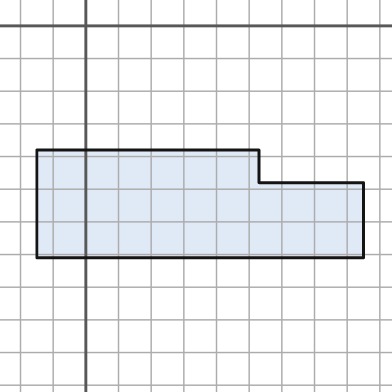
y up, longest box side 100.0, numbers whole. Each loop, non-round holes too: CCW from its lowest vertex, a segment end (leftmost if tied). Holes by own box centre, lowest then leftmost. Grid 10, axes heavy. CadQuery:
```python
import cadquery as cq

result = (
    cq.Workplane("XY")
    .moveTo(-15.0, -71.0)
    .lineTo(85.0, -71.0)
    .lineTo(85.0, -48.0)
    .lineTo(53.0, -48.0)
    .lineTo(53.0, -38.0)
    .lineTo(-15.0, -38.0)
    .close()
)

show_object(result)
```